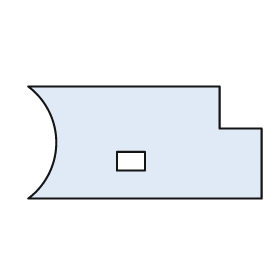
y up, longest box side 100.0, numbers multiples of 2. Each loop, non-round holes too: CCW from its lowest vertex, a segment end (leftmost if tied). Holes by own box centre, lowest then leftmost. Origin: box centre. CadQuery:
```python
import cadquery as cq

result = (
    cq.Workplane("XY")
    .moveTo(-50.0, -24.0)
    .lineTo(50.0, -24.0)
    .lineTo(50.0, 6.0)
    .lineTo(32.0, 6.0)
    .lineTo(32.0, 24.0)
    .lineTo(-50.0, 24.0)
    .threePointArc((-38.0, 0.0), (-50.0, -24.0))
    .close()
    .moveTo(-12.0, -12.0)
    .lineTo(0.0, -12.0)
    .lineTo(0.0, -4.0)
    .lineTo(-12.0, -4.0)
    .close()
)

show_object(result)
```